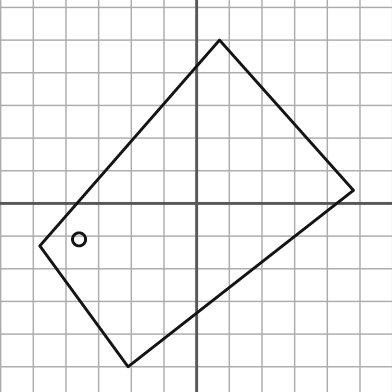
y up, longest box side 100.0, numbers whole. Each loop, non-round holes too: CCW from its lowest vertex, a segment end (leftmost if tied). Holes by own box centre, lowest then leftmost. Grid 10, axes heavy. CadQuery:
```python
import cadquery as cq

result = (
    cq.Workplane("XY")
    .moveTo(-21.0, -50.0)
    .lineTo(48.0, 4.0)
    .lineTo(7.0, 50.0)
    .lineTo(-48.0, -13.0)
    .close()
    .moveTo(-36.0, -11.0)
    .circle(2.0)
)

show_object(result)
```